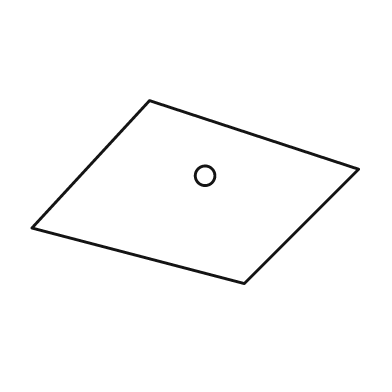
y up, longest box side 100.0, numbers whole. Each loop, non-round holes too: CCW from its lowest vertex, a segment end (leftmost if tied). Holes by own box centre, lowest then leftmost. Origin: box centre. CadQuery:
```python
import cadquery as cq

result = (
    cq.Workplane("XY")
    .moveTo(15.0, -28.0)
    .lineTo(50.0, 7.0)
    .lineTo(-14.0, 28.0)
    .lineTo(-50.0, -11.0)
    .close()
    .moveTo(3.0, 5.0)
    .circle(3.0)
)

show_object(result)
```